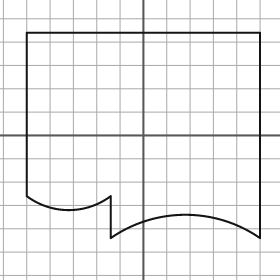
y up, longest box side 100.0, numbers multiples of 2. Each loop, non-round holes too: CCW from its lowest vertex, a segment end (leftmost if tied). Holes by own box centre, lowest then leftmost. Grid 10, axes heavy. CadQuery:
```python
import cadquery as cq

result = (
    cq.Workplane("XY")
    .moveTo(-14.0, -44.0)
    .threePointArc((18.0, -34.0), (50.0, -44.0))
    .lineTo(50.0, 44.0)
    .lineTo(-50.0, 44.0)
    .lineTo(-50.0, -26.0)
    .threePointArc((-32.0, -32.0), (-14.0, -26.0))
    .close()
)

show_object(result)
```